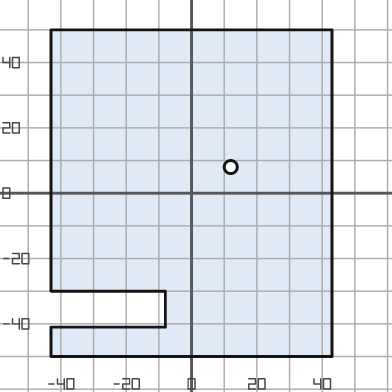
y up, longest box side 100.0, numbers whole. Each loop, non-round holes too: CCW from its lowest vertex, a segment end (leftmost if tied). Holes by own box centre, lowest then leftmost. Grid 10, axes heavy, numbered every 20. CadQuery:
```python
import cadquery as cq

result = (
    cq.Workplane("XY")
    .moveTo(-43.0, -50.0)
    .lineTo(43.0, -50.0)
    .lineTo(43.0, 50.0)
    .lineTo(-43.0, 50.0)
    .lineTo(-43.0, -30.0)
    .lineTo(-8.0, -30.0)
    .lineTo(-8.0, -41.0)
    .lineTo(-43.0, -41.0)
    .close()
    .moveTo(12.0, 8.0)
    .circle(2.0)
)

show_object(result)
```